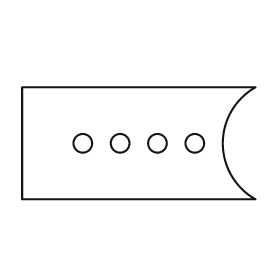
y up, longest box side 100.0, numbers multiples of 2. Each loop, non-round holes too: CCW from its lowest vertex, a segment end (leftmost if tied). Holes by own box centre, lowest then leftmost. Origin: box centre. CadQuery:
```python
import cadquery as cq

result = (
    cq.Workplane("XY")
    .moveTo(-50.0, -24.0)
    .lineTo(50.0, -24.0)
    .threePointArc((36.0, 0.0), (50.0, 24.0))
    .lineTo(-50.0, 24.0)
    .close()
    .moveTo(-24.0, 0.0)
    .circle(4.0)
    .moveTo(-8.0, 0.0)
    .circle(4.0)
    .moveTo(8.0, 0.0)
    .circle(4.0)
    .moveTo(24.0, 0.0)
    .circle(4.0)
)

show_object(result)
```